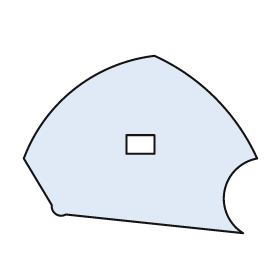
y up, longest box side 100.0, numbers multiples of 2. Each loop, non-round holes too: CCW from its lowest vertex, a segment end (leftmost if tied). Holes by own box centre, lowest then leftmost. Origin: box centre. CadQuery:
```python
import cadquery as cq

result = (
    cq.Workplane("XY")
    .moveTo(44.0, -38.0)
    .threePointArc((36.0, -20.0), (50.0, -6.0))
    .threePointArc((32.0, 20.0), (6.0, 38.0))
    .threePointArc((-28.0, 24.0), (-50.0, -6.0))
    .lineTo(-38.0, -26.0)
    .threePointArc((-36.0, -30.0), (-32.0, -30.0))
    .close()
    .moveTo(-6.0, -4.0)
    .lineTo(6.0, -4.0)
    .lineTo(6.0, 4.0)
    .lineTo(-6.0, 4.0)
    .close()
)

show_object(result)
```